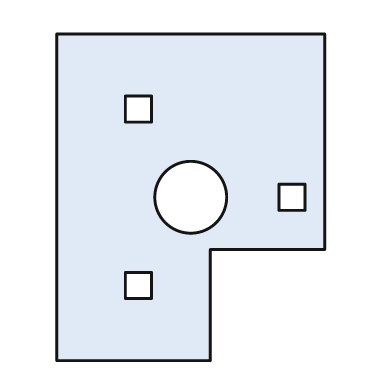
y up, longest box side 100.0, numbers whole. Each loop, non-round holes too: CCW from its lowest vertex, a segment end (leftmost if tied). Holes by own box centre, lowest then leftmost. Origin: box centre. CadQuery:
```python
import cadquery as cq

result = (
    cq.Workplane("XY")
    .moveTo(-41.0, -50.0)
    .lineTo(6.0, -50.0)
    .lineTo(6.0, -16.0)
    .lineTo(41.0, -16.0)
    .lineTo(41.0, 50.0)
    .lineTo(-41.0, 50.0)
    .close()
    .moveTo(-20.0, -31.0)
    .lineTo(-12.0, -31.0)
    .lineTo(-12.0, -23.0)
    .lineTo(-20.0, -23.0)
    .close()
    .moveTo(0.0, 0.0)
    .circle(11.0)
    .moveTo(27.0, -4.0)
    .lineTo(35.0, -4.0)
    .lineTo(35.0, 4.0)
    .lineTo(27.0, 4.0)
    .close()
    .moveTo(-20.0, 23.0)
    .lineTo(-12.0, 23.0)
    .lineTo(-12.0, 31.0)
    .lineTo(-20.0, 31.0)
    .close()
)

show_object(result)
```